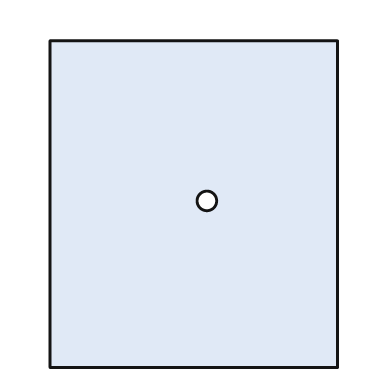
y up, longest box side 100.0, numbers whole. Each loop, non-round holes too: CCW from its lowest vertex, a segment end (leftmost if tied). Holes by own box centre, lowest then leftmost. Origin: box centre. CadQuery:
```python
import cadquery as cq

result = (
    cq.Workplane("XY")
    .moveTo(-44.0, -50.0)
    .lineTo(44.0, -50.0)
    .lineTo(44.0, 50.0)
    .lineTo(-44.0, 50.0)
    .close()
    .moveTo(4.0, 1.0)
    .circle(3.0)
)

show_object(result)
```